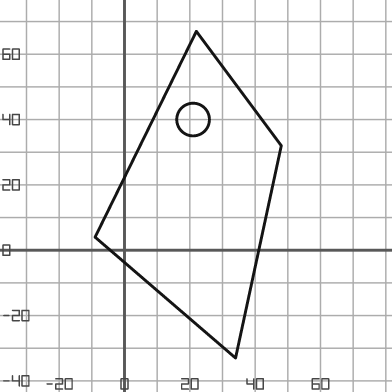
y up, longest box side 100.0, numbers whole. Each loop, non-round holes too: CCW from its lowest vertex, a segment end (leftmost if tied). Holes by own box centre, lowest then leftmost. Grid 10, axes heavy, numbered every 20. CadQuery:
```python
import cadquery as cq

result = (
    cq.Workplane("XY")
    .moveTo(34.0, -33.0)
    .lineTo(48.0, 32.0)
    .lineTo(22.0, 67.0)
    .lineTo(-9.0, 4.0)
    .close()
    .moveTo(21.0, 40.0)
    .circle(5.0)
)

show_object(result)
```